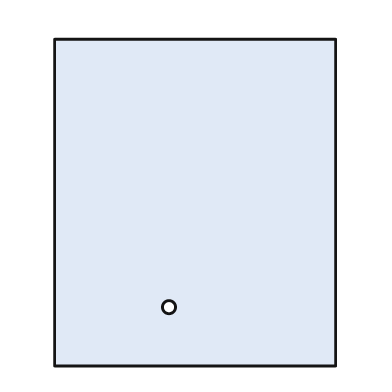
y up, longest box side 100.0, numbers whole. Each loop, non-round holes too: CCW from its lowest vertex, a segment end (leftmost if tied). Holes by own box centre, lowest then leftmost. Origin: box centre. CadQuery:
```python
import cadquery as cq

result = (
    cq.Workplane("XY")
    .moveTo(-43.0, -50.0)
    .lineTo(43.0, -50.0)
    .lineTo(43.0, 50.0)
    .lineTo(-43.0, 50.0)
    .close()
    .moveTo(-8.0, -32.0)
    .circle(2.0)
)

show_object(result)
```